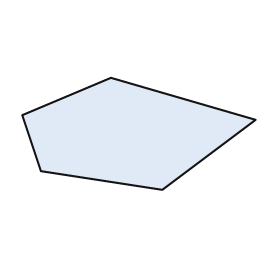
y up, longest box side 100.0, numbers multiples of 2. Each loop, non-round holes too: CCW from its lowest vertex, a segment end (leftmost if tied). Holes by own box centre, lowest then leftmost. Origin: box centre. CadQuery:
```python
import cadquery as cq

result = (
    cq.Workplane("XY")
    .moveTo(10.0, -24.0)
    .lineTo(50.0, 6.0)
    .lineTo(-12.0, 24.0)
    .lineTo(-50.0, 8.0)
    .lineTo(-42.0, -16.0)
    .close()
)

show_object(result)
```